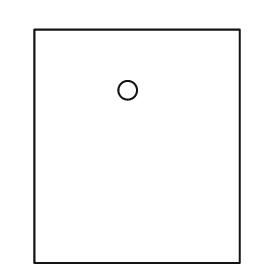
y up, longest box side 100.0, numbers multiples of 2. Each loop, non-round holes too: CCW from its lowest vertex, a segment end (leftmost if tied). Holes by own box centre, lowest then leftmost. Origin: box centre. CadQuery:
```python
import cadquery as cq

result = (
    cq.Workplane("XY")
    .moveTo(-44.0, -50.0)
    .lineTo(44.0, -50.0)
    .lineTo(44.0, 50.0)
    .lineTo(-44.0, 50.0)
    .close()
    .moveTo(-4.0, 24.0)
    .circle(4.0)
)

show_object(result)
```